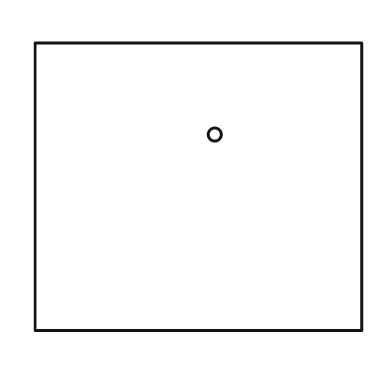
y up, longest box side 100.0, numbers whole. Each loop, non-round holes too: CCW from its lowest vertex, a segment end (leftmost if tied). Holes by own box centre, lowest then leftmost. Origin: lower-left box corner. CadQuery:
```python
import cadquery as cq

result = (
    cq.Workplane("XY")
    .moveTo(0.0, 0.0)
    .lineTo(100.0, 0.0)
    .lineTo(100.0, 88.0)
    .lineTo(0.0, 88.0)
    .close()
    .moveTo(55.0, 60.0)
    .circle(2.0)
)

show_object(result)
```